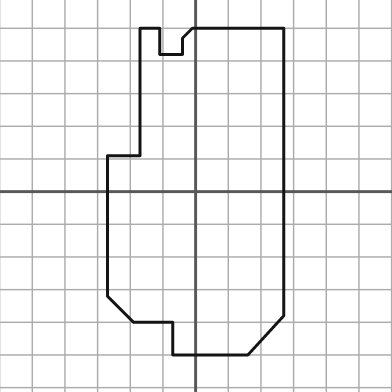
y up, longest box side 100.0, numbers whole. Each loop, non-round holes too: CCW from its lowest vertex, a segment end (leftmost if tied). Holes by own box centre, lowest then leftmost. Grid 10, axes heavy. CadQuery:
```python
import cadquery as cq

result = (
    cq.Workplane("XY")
    .moveTo(-7.0, -50.0)
    .lineTo(16.0, -50.0)
    .lineTo(27.0, -38.0)
    .lineTo(27.0, 50.0)
    .lineTo(-1.0, 50.0)
    .lineTo(-4.0, 47.0)
    .lineTo(-4.0, 42.0)
    .lineTo(-11.0, 42.0)
    .lineTo(-11.0, 50.0)
    .lineTo(-17.0, 50.0)
    .lineTo(-17.0, 11.0)
    .lineTo(-27.0, 11.0)
    .lineTo(-27.0, -32.0)
    .lineTo(-19.0, -40.0)
    .lineTo(-7.0, -40.0)
    .close()
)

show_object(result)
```